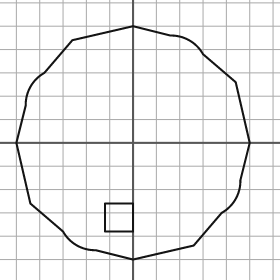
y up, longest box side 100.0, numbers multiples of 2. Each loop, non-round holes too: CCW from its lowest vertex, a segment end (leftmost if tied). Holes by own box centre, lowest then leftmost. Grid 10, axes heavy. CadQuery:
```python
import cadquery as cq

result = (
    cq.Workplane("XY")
    .moveTo(0.0, -50.0)
    .lineTo(26.0, -44.0)
    .lineTo(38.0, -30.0)
    .threePointArc((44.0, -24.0), (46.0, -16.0))
    .lineTo(50.0, 0.0)
    .lineTo(44.0, 26.0)
    .lineTo(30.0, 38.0)
    .threePointArc((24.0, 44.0), (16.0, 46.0))
    .lineTo(0.0, 50.0)
    .lineTo(-26.0, 44.0)
    .lineTo(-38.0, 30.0)
    .threePointArc((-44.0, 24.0), (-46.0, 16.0))
    .lineTo(-50.0, 0.0)
    .lineTo(-44.0, -26.0)
    .lineTo(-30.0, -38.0)
    .threePointArc((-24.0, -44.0), (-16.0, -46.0))
    .close()
    .moveTo(-12.0, -38.0)
    .lineTo(0.0, -38.0)
    .lineTo(0.0, -26.0)
    .lineTo(-12.0, -26.0)
    .close()
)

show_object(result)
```